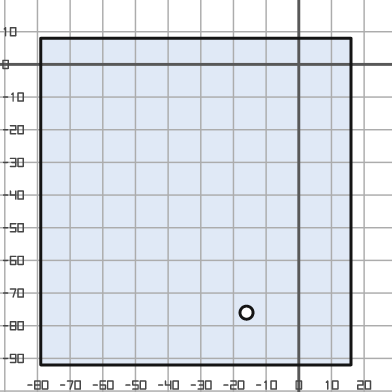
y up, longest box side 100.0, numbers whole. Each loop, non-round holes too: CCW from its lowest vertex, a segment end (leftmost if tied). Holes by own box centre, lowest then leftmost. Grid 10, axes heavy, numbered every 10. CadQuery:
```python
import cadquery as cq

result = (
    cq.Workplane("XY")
    .moveTo(-79.0, -92.0)
    .lineTo(16.0, -92.0)
    .lineTo(16.0, 8.0)
    .lineTo(-79.0, 8.0)
    .close()
    .moveTo(-16.0, -76.0)
    .circle(2.0)
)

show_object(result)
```